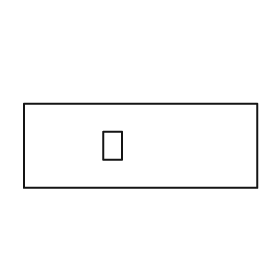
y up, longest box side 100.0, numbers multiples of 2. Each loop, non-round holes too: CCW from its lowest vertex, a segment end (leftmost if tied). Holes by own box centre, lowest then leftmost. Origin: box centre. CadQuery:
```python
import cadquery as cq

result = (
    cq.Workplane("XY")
    .moveTo(-50.0, -18.0)
    .lineTo(50.0, -18.0)
    .lineTo(50.0, 18.0)
    .lineTo(-50.0, 18.0)
    .close()
    .moveTo(-16.0, -6.0)
    .lineTo(-8.0, -6.0)
    .lineTo(-8.0, 6.0)
    .lineTo(-16.0, 6.0)
    .close()
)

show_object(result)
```